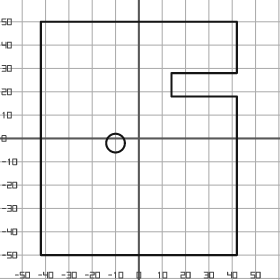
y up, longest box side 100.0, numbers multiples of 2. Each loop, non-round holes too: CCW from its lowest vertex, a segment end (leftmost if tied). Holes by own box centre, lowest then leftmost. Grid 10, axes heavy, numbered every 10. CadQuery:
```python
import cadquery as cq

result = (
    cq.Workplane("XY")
    .moveTo(-42.0, -50.0)
    .lineTo(42.0, -50.0)
    .lineTo(42.0, 18.0)
    .lineTo(14.0, 18.0)
    .lineTo(14.0, 28.0)
    .lineTo(42.0, 28.0)
    .lineTo(42.0, 50.0)
    .lineTo(-42.0, 50.0)
    .close()
    .moveTo(-10.0, -2.0)
    .circle(4.0)
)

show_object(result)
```